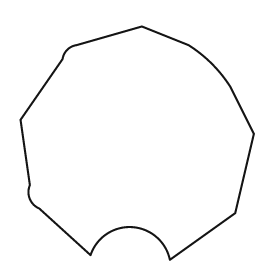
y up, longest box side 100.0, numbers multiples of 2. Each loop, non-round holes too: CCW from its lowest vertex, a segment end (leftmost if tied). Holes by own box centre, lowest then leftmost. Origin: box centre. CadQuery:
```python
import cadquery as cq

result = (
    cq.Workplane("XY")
    .moveTo(14.0, -50.0)
    .lineTo(42.0, -30.0)
    .lineTo(50.0, 4.0)
    .lineTo(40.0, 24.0)
    .threePointArc((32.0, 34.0), (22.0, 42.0))
    .lineTo(2.0, 50.0)
    .lineTo(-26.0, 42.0)
    .threePointArc((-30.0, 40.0), (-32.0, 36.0))
    .lineTo(-50.0, 10.0)
    .lineTo(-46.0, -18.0)
    .threePointArc((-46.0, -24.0), (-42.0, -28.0))
    .lineTo(-20.0, -48.0)
    .threePointArc((-2.0, -36.0), (14.0, -50.0))
    .close()
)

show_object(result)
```